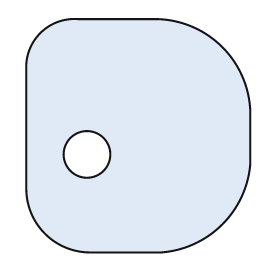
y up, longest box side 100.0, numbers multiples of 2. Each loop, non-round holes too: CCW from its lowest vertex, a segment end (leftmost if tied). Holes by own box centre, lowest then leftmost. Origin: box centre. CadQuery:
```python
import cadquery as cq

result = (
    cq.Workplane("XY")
    .moveTo(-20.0, -50.0)
    .lineTo(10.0, -50.0)
    .threePointArc((36.0, -38.0), (48.0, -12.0))
    .lineTo(48.0, 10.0)
    .threePointArc((36.0, 38.0), (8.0, 50.0))
    .lineTo(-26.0, 50.0)
    .threePointArc((-42.0, 44.0), (-48.0, 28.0))
    .lineTo(-48.0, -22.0)
    .threePointArc((-40.0, -42.0), (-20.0, -50.0))
    .close()
    .moveTo(-22.0, -8.0)
    .circle(10.0)
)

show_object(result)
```